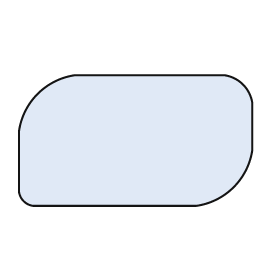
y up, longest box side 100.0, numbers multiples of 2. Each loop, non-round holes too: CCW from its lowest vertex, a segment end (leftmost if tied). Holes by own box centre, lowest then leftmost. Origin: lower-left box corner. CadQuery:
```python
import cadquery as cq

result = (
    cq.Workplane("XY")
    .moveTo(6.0, 0.0)
    .lineTo(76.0, 0.0)
    .threePointArc((92.0, 8.0), (100.0, 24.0))
    .lineTo(100.0, 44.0)
    .threePointArc((96.0, 52.0), (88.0, 56.0))
    .lineTo(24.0, 56.0)
    .threePointArc((8.0, 48.0), (0.0, 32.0))
    .lineTo(0.0, 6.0)
    .threePointArc((2.0, 2.0), (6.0, 0.0))
    .close()
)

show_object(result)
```